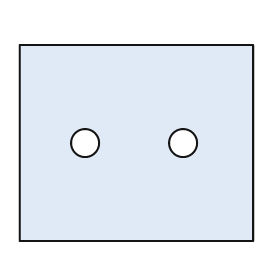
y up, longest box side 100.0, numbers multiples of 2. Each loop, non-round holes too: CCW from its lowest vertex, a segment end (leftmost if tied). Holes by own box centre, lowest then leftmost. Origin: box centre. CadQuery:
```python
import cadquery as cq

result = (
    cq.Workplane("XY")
    .moveTo(-50.0, -42.0)
    .lineTo(50.0, -42.0)
    .lineTo(50.0, 42.0)
    .lineTo(-50.0, 42.0)
    .close()
    .moveTo(-22.0, 0.0)
    .circle(6.0)
    .moveTo(20.0, 0.0)
    .circle(6.0)
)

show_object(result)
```